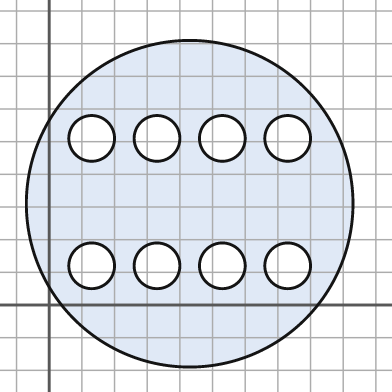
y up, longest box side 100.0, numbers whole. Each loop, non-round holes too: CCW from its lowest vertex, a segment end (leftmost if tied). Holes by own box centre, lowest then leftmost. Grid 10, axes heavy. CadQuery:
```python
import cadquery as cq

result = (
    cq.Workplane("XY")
    .moveTo(43.0, 31.0)
    .circle(50.0)
    .moveTo(13.0, 12.0)
    .circle(7.0)
    .moveTo(33.0, 12.0)
    .circle(7.0)
    .moveTo(53.0, 12.0)
    .circle(7.0)
    .moveTo(73.0, 12.0)
    .circle(7.0)
    .moveTo(13.0, 51.0)
    .circle(7.0)
    .moveTo(33.0, 51.0)
    .circle(7.0)
    .moveTo(53.0, 51.0)
    .circle(7.0)
    .moveTo(73.0, 51.0)
    .circle(7.0)
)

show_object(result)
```